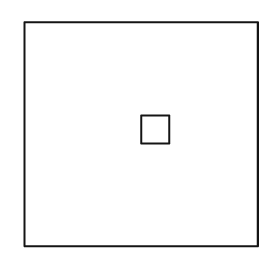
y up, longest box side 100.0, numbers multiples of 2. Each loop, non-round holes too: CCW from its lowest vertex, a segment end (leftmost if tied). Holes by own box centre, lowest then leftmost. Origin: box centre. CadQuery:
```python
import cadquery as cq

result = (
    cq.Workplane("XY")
    .moveTo(-50.0, -48.0)
    .lineTo(50.0, -48.0)
    .lineTo(50.0, 48.0)
    .lineTo(-50.0, 48.0)
    .close()
    .moveTo(0.0, -4.0)
    .lineTo(12.0, -4.0)
    .lineTo(12.0, 8.0)
    .lineTo(0.0, 8.0)
    .close()
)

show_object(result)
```